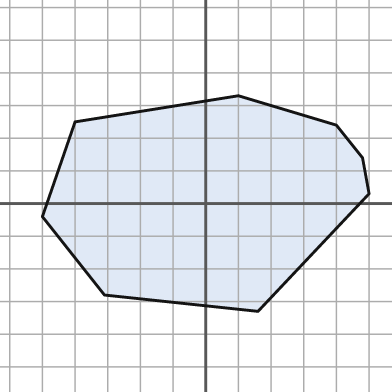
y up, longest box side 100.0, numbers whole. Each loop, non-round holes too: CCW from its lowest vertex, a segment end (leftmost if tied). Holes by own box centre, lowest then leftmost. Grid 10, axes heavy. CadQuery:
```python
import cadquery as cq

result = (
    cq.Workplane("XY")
    .moveTo(16.0, -33.0)
    .lineTo(50.0, 3.0)
    .lineTo(48.0, 14.0)
    .lineTo(40.0, 24.0)
    .lineTo(10.0, 33.0)
    .lineTo(-40.0, 25.0)
    .lineTo(-50.0, -4.0)
    .lineTo(-31.0, -28.0)
    .close()
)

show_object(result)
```